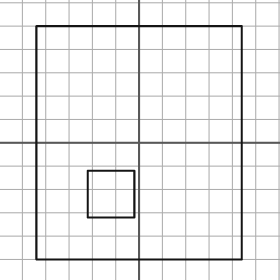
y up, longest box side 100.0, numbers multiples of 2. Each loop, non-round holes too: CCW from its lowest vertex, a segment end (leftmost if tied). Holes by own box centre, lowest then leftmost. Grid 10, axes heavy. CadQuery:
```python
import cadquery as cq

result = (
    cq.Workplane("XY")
    .moveTo(-44.0, -50.0)
    .lineTo(44.0, -50.0)
    .lineTo(44.0, 50.0)
    .lineTo(-44.0, 50.0)
    .close()
    .moveTo(-22.0, -32.0)
    .lineTo(-2.0, -32.0)
    .lineTo(-2.0, -12.0)
    .lineTo(-22.0, -12.0)
    .close()
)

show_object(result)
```